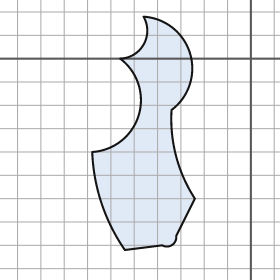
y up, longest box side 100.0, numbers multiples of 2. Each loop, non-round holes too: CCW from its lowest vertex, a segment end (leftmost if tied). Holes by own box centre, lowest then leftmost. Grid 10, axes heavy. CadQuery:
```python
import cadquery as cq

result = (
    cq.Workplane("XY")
    .moveTo(-54.0, -82.0)
    .lineTo(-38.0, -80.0)
    .threePointArc((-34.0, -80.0), (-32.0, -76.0))
    .lineTo(-24.0, -60.0)
    .threePointArc((-32.0, -42.0), (-34.0, -22.0))
    .threePointArc((-26.0, 2.0), (-46.0, 18.0))
    .threePointArc((-46.0, 6.0), (-56.0, 0.0))
    .threePointArc((-48.0, -24.0), (-68.0, -40.0))
    .threePointArc((-64.0, -62.0), (-54.0, -82.0))
    .close()
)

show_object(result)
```